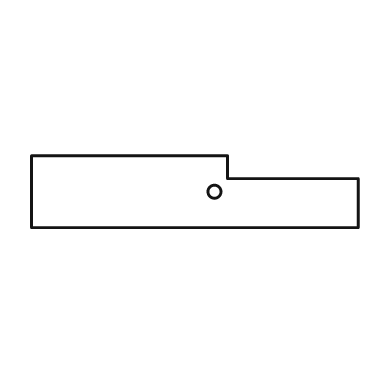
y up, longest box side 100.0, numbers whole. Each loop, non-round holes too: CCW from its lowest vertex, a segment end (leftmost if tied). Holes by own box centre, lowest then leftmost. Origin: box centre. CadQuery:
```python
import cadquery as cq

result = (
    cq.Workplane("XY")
    .moveTo(-50.0, -11.0)
    .lineTo(50.0, -11.0)
    .lineTo(50.0, 4.0)
    .lineTo(10.0, 4.0)
    .lineTo(10.0, 11.0)
    .lineTo(-50.0, 11.0)
    .close()
    .moveTo(6.0, 0.0)
    .circle(2.0)
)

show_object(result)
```